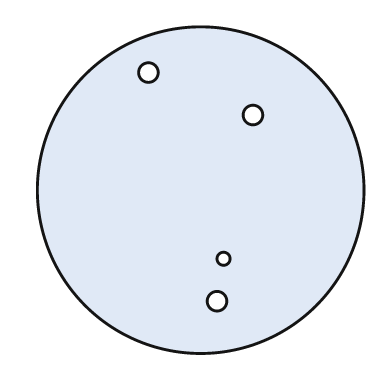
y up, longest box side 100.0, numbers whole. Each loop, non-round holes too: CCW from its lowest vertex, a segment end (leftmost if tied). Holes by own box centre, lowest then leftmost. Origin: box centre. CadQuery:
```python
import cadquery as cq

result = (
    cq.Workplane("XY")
    .moveTo(0.0, 0.0)
    .circle(50.0)
    .moveTo(5.0, -34.0)
    .circle(3.0)
    .moveTo(7.0, -21.0)
    .circle(2.0)
    .moveTo(16.0, 23.0)
    .circle(3.0)
    .moveTo(-16.0, 36.0)
    .circle(3.0)
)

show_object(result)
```